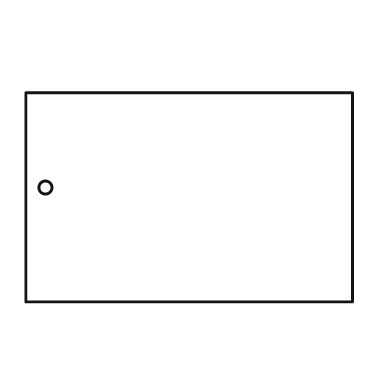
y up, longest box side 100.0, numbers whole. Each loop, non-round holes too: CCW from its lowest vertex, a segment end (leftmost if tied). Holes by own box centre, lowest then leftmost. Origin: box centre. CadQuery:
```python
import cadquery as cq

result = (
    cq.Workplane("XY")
    .moveTo(-50.0, -32.0)
    .lineTo(50.0, -32.0)
    .lineTo(50.0, 32.0)
    .lineTo(-50.0, 32.0)
    .close()
    .moveTo(-44.0, 3.0)
    .circle(2.0)
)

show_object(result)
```